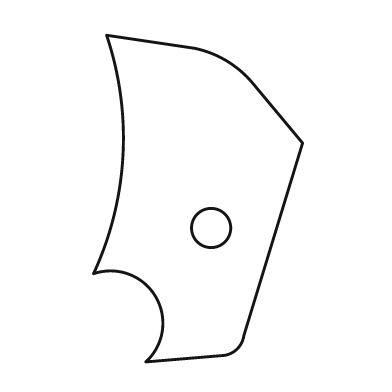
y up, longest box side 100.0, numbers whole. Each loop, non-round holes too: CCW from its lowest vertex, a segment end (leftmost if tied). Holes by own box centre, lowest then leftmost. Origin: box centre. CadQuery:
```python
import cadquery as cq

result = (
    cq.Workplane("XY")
    .moveTo(-16.0, -50.0)
    .lineTo(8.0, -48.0)
    .threePointArc((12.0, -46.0), (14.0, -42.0))
    .lineTo(32.0, 17.0)
    .lineTo(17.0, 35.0)
    .threePointArc((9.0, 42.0), (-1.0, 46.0))
    .lineTo(-28.0, 50.0)
    .threePointArc((-23.0, 13.0), (-32.0, -23.0))
    .threePointArc((-13.0, -30.0), (-16.0, -50.0))
    .close()
    .moveTo(4.0, -9.0)
    .circle(6.0)
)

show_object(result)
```